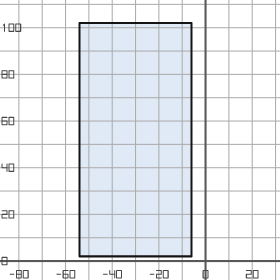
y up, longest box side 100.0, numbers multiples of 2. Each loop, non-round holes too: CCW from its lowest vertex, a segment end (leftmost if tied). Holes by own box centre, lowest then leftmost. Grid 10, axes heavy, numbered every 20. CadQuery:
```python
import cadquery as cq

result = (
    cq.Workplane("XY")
    .moveTo(-54.0, 2.0)
    .lineTo(-6.0, 2.0)
    .lineTo(-6.0, 102.0)
    .lineTo(-54.0, 102.0)
    .close()
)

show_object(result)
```